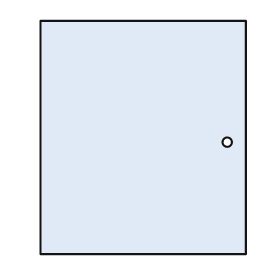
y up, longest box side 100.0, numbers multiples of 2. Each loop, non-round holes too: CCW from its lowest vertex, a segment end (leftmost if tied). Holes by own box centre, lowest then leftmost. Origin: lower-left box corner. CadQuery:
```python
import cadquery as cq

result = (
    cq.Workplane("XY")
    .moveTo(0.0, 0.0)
    .lineTo(88.0, 0.0)
    .lineTo(88.0, 100.0)
    .lineTo(0.0, 100.0)
    .close()
    .moveTo(80.0, 48.0)
    .circle(2.0)
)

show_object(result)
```